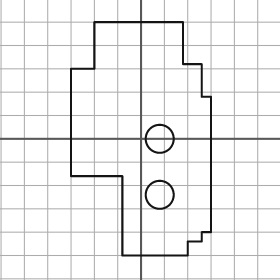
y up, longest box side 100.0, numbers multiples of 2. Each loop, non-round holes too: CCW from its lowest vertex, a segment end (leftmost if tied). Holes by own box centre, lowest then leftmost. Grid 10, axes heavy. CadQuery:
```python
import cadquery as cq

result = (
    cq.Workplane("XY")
    .moveTo(-8.0, -50.0)
    .lineTo(20.0, -50.0)
    .lineTo(20.0, -44.0)
    .lineTo(26.0, -44.0)
    .lineTo(26.0, -40.0)
    .lineTo(30.0, -40.0)
    .lineTo(30.0, 18.0)
    .lineTo(26.0, 18.0)
    .lineTo(26.0, 32.0)
    .lineTo(18.0, 32.0)
    .lineTo(18.0, 50.0)
    .lineTo(-20.0, 50.0)
    .lineTo(-20.0, 30.0)
    .lineTo(-30.0, 30.0)
    .lineTo(-30.0, -16.0)
    .lineTo(-8.0, -16.0)
    .close()
    .moveTo(8.0, -24.0)
    .circle(6.0)
    .moveTo(8.0, 0.0)
    .circle(6.0)
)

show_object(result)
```